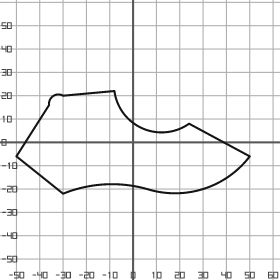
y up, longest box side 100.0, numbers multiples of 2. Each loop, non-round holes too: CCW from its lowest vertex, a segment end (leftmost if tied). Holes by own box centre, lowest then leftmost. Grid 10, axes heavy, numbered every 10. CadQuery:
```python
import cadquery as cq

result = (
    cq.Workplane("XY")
    .moveTo(-30.0, -22.0)
    .threePointArc((-12.0, -18.0), (6.0, -20.0))
    .threePointArc((30.0, -20.0), (50.0, -6.0))
    .lineTo(24.0, 8.0)
    .threePointArc((4.0, 6.0), (-8.0, 22.0))
    .lineTo(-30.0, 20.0)
    .threePointArc((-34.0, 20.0), (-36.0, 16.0))
    .lineTo(-50.0, -6.0)
    .close()
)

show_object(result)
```